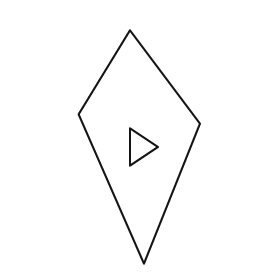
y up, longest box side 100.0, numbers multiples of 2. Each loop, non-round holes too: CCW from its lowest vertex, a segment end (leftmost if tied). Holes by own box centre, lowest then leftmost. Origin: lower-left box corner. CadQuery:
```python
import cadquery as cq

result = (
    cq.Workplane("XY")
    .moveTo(28.0, 0.0)
    .lineTo(52.0, 60.0)
    .lineTo(22.0, 100.0)
    .lineTo(0.0, 64.0)
    .close()
    .moveTo(22.0, 42.0)
    .lineTo(34.0, 50.0)
    .lineTo(22.0, 58.0)
    .close()
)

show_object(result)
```